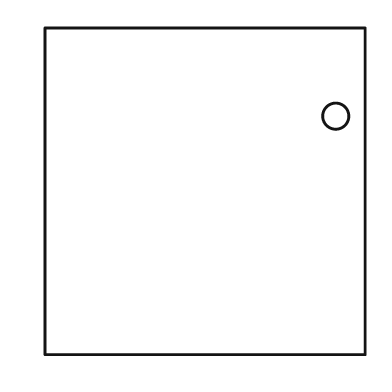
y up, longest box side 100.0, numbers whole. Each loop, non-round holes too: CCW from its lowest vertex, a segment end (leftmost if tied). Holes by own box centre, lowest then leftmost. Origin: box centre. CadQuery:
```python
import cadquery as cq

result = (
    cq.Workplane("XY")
    .moveTo(-49.0, -50.0)
    .lineTo(49.0, -50.0)
    .lineTo(49.0, 50.0)
    .lineTo(-49.0, 50.0)
    .close()
    .moveTo(40.0, 23.0)
    .circle(4.0)
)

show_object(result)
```